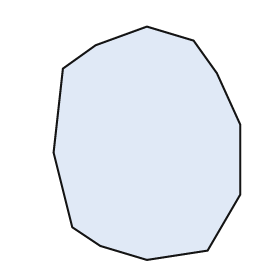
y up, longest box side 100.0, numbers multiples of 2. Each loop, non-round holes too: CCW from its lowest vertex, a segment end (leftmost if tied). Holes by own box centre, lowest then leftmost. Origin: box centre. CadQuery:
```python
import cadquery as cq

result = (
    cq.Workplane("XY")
    .moveTo(0.0, -50.0)
    .lineTo(26.0, -46.0)
    .lineTo(40.0, -22.0)
    .lineTo(40.0, 8.0)
    .lineTo(30.0, 30.0)
    .lineTo(20.0, 44.0)
    .lineTo(0.0, 50.0)
    .lineTo(-22.0, 42.0)
    .lineTo(-36.0, 32.0)
    .lineTo(-40.0, -4.0)
    .lineTo(-32.0, -36.0)
    .lineTo(-20.0, -44.0)
    .close()
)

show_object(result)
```